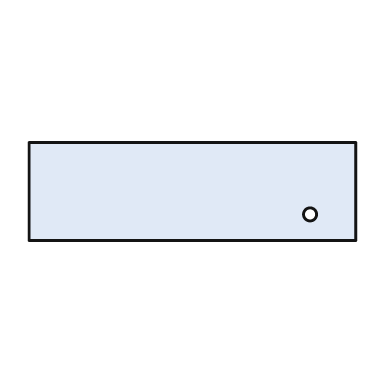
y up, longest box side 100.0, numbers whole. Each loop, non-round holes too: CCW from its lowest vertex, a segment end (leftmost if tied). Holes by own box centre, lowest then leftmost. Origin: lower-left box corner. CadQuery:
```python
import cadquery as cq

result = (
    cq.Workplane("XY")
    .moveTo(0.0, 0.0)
    .lineTo(100.0, 0.0)
    .lineTo(100.0, 30.0)
    .lineTo(0.0, 30.0)
    .close()
    .moveTo(86.0, 8.0)
    .circle(2.0)
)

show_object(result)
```